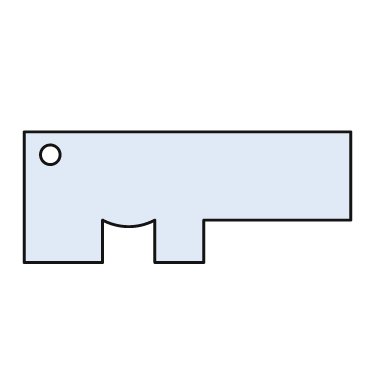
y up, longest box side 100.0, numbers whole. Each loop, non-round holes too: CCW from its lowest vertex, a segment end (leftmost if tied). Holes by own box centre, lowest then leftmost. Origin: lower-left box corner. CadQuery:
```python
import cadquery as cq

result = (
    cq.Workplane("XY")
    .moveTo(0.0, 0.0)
    .lineTo(24.0, 0.0)
    .lineTo(24.0, 13.0)
    .threePointArc((32.0, 11.0), (40.0, 13.0))
    .lineTo(40.0, 0.0)
    .lineTo(55.0, 0.0)
    .lineTo(55.0, 13.0)
    .lineTo(100.0, 13.0)
    .lineTo(100.0, 40.0)
    .lineTo(0.0, 40.0)
    .close()
    .moveTo(8.0, 33.0)
    .circle(3.0)
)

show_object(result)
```